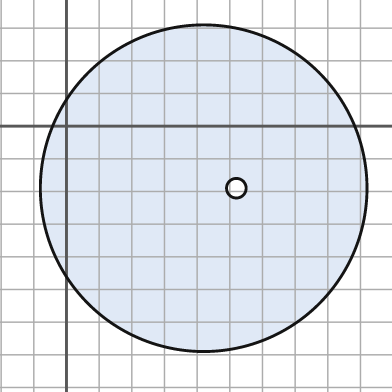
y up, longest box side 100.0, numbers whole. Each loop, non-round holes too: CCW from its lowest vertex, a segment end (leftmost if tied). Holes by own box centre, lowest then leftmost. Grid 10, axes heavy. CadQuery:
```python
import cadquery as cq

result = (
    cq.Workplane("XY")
    .moveTo(42.0, -19.0)
    .circle(50.0)
    .moveTo(52.0, -19.0)
    .circle(3.0)
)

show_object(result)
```